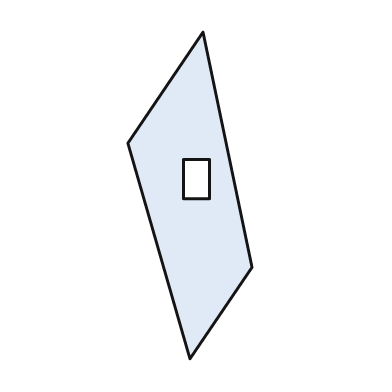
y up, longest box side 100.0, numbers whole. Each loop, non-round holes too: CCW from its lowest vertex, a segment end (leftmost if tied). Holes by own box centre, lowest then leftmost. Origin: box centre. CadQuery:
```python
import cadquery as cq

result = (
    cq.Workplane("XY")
    .moveTo(0.0, -50.0)
    .lineTo(19.0, -22.0)
    .lineTo(4.0, 50.0)
    .lineTo(-19.0, 16.0)
    .close()
    .moveTo(-2.0, -1.0)
    .lineTo(6.0, -1.0)
    .lineTo(6.0, 11.0)
    .lineTo(-2.0, 11.0)
    .close()
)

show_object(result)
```